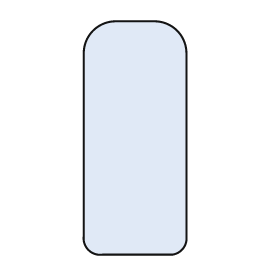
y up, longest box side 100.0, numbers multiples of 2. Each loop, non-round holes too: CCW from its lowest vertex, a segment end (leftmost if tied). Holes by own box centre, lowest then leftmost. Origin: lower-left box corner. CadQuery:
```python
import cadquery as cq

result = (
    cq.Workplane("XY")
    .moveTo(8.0, 0.0)
    .lineTo(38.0, 0.0)
    .threePointArc((42.0, 2.0), (44.0, 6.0))
    .lineTo(44.0, 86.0)
    .threePointArc((40.0, 96.0), (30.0, 100.0))
    .lineTo(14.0, 100.0)
    .threePointArc((4.0, 96.0), (0.0, 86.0))
    .lineTo(0.0, 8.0)
    .threePointArc((2.0, 2.0), (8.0, 0.0))
    .close()
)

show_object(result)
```